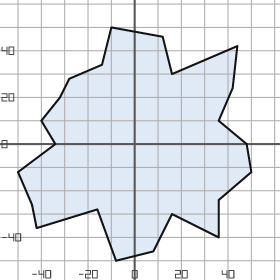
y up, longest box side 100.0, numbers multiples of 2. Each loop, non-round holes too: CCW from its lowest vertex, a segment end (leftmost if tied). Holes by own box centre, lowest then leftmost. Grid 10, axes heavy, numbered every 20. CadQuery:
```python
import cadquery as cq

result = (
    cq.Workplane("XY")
    .moveTo(-8.0, -50.0)
    .lineTo(8.0, -46.0)
    .lineTo(16.0, -30.0)
    .lineTo(36.0, -40.0)
    .lineTo(36.0, -24.0)
    .lineTo(50.0, -12.0)
    .lineTo(48.0, 0.0)
    .lineTo(36.0, 10.0)
    .lineTo(42.0, 24.0)
    .lineTo(44.0, 42.0)
    .lineTo(16.0, 30.0)
    .lineTo(12.0, 46.0)
    .lineTo(-10.0, 50.0)
    .lineTo(-14.0, 34.0)
    .lineTo(-28.0, 28.0)
    .lineTo(-32.0, 20.0)
    .lineTo(-40.0, 10.0)
    .lineTo(-34.0, 0.0)
    .lineTo(-50.0, -12.0)
    .lineTo(-44.0, -26.0)
    .lineTo(-42.0, -36.0)
    .lineTo(-16.0, -28.0)
    .close()
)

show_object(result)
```